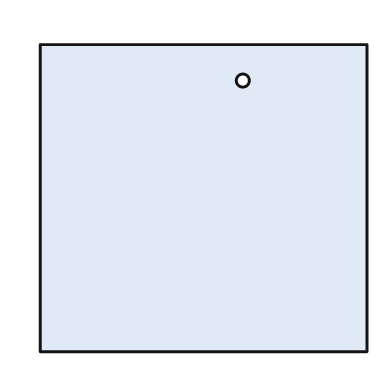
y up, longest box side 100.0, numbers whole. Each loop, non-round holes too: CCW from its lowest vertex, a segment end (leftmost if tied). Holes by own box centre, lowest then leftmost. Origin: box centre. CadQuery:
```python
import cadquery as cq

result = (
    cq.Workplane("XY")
    .moveTo(-50.0, -47.0)
    .lineTo(50.0, -47.0)
    .lineTo(50.0, 47.0)
    .lineTo(-50.0, 47.0)
    .close()
    .moveTo(12.0, 36.0)
    .circle(2.0)
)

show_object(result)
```